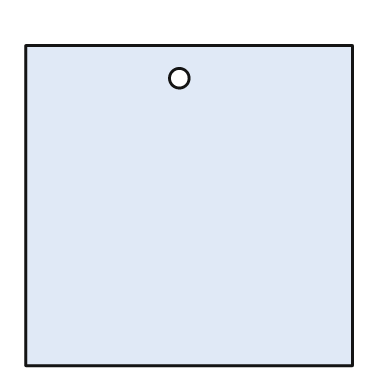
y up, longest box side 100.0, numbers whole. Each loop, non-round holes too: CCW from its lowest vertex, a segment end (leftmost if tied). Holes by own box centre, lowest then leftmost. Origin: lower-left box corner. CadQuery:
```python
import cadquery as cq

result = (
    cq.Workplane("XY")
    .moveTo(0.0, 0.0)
    .lineTo(100.0, 0.0)
    .lineTo(100.0, 98.0)
    .lineTo(0.0, 98.0)
    .close()
    .moveTo(47.0, 88.0)
    .circle(3.0)
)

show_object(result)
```